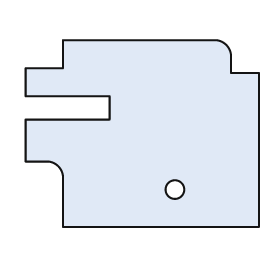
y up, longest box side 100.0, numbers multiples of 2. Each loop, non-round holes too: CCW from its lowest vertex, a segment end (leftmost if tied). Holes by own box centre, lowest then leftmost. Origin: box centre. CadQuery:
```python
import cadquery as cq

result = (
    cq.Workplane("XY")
    .moveTo(-34.0, -40.0)
    .lineTo(50.0, -40.0)
    .lineTo(50.0, 26.0)
    .lineTo(38.0, 26.0)
    .lineTo(38.0, 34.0)
    .threePointArc((36.0, 38.0), (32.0, 40.0))
    .lineTo(-34.0, 40.0)
    .lineTo(-34.0, 28.0)
    .lineTo(-50.0, 28.0)
    .lineTo(-50.0, 16.0)
    .lineTo(-14.0, 16.0)
    .lineTo(-14.0, 6.0)
    .lineTo(-50.0, 6.0)
    .lineTo(-50.0, -12.0)
    .lineTo(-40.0, -12.0)
    .threePointArc((-36.0, -14.0), (-34.0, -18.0))
    .close()
    .moveTo(14.0, -24.0)
    .circle(4.0)
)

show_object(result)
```